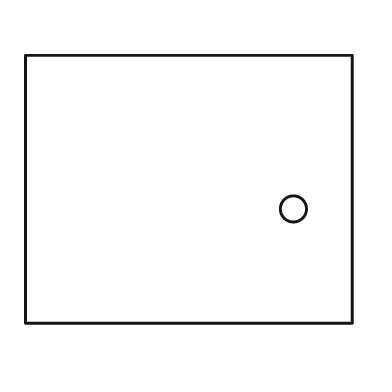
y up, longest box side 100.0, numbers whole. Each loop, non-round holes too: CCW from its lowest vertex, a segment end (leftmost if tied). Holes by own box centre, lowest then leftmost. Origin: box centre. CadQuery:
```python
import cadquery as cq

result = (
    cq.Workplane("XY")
    .moveTo(-50.0, -41.0)
    .lineTo(50.0, -41.0)
    .lineTo(50.0, 41.0)
    .lineTo(-50.0, 41.0)
    .close()
    .moveTo(32.0, -6.0)
    .circle(4.0)
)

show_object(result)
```